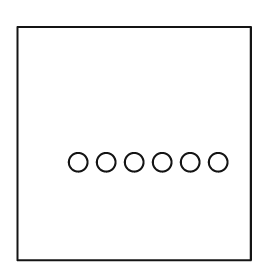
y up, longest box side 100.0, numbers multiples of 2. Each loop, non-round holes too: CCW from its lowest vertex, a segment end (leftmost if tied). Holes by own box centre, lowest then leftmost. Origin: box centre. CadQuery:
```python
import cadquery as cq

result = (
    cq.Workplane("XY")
    .moveTo(-50.0, -50.0)
    .lineTo(50.0, -50.0)
    .lineTo(50.0, 50.0)
    .lineTo(-50.0, 50.0)
    .close()
    .moveTo(-24.0, -8.0)
    .circle(4.0)
    .moveTo(-12.0, -8.0)
    .circle(4.0)
    .moveTo(0.0, -8.0)
    .circle(4.0)
    .moveTo(12.0, -8.0)
    .circle(4.0)
    .moveTo(24.0, -8.0)
    .circle(4.0)
    .moveTo(36.0, -8.0)
    .circle(4.0)
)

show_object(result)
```